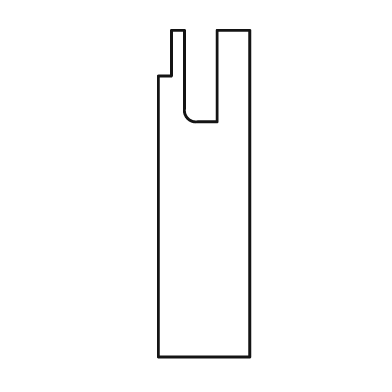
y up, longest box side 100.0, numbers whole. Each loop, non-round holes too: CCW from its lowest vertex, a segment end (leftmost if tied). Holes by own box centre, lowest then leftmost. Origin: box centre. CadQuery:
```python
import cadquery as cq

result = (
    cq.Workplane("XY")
    .moveTo(-14.0, -50.0)
    .lineTo(14.0, -50.0)
    .lineTo(14.0, 50.0)
    .lineTo(4.0, 50.0)
    .lineTo(4.0, 22.0)
    .lineTo(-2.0, 22.0)
    .threePointArc((-5.0, 23.0), (-6.0, 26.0))
    .lineTo(-6.0, 50.0)
    .lineTo(-10.0, 50.0)
    .lineTo(-10.0, 36.0)
    .lineTo(-14.0, 36.0)
    .close()
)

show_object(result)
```